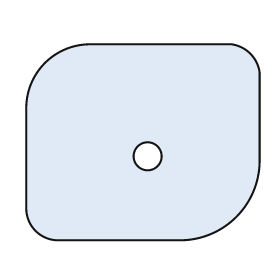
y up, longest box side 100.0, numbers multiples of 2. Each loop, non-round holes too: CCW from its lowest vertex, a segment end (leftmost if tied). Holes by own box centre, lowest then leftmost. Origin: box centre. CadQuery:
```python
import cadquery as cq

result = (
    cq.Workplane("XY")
    .moveTo(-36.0, -42.0)
    .lineTo(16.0, -42.0)
    .threePointArc((40.0, -32.0), (50.0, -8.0))
    .lineTo(50.0, 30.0)
    .threePointArc((46.0, 38.0), (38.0, 42.0))
    .lineTo(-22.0, 42.0)
    .threePointArc((-42.0, 34.0), (-50.0, 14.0))
    .lineTo(-50.0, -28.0)
    .threePointArc((-46.0, -38.0), (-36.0, -42.0))
    .close()
    .moveTo(2.0, -6.0)
    .circle(6.0)
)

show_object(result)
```